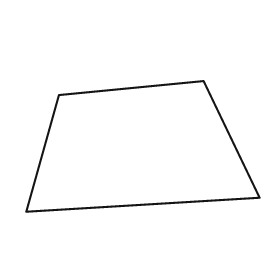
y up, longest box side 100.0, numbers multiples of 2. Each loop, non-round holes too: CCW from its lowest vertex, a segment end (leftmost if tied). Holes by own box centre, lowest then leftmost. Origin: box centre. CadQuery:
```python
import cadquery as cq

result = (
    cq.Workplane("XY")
    .moveTo(-50.0, -28.0)
    .lineTo(50.0, -22.0)
    .lineTo(26.0, 28.0)
    .lineTo(-36.0, 22.0)
    .close()
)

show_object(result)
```